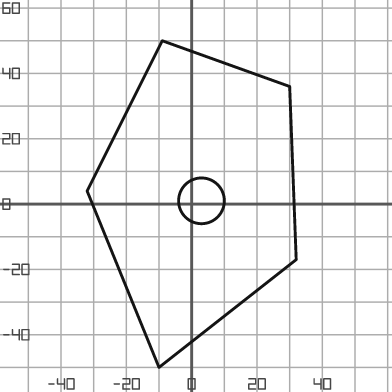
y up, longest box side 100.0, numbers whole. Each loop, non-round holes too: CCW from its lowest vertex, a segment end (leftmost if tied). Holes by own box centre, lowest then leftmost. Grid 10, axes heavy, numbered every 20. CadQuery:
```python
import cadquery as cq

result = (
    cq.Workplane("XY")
    .moveTo(-10.0, -50.0)
    .lineTo(32.0, -17.0)
    .lineTo(30.0, 36.0)
    .lineTo(-9.0, 50.0)
    .lineTo(-32.0, 4.0)
    .close()
    .moveTo(3.0, 1.0)
    .circle(7.0)
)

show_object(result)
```